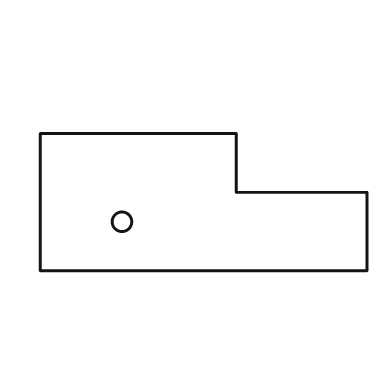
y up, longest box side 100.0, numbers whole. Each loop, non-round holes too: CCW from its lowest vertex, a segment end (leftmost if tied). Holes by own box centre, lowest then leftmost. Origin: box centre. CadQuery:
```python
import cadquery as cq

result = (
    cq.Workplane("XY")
    .moveTo(-50.0, -21.0)
    .lineTo(50.0, -21.0)
    .lineTo(50.0, 3.0)
    .lineTo(10.0, 3.0)
    .lineTo(10.0, 21.0)
    .lineTo(-50.0, 21.0)
    .close()
    .moveTo(-25.0, -6.0)
    .circle(3.0)
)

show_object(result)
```